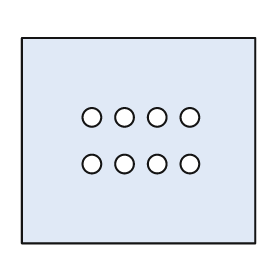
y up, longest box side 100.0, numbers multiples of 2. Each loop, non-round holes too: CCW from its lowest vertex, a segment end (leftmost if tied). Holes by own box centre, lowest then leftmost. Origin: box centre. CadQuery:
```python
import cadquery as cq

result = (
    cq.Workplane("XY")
    .moveTo(-50.0, -44.0)
    .lineTo(50.0, -44.0)
    .lineTo(50.0, 44.0)
    .lineTo(-50.0, 44.0)
    .close()
    .moveTo(-20.0, -10.0)
    .circle(4.0)
    .moveTo(-6.0, -10.0)
    .circle(4.0)
    .moveTo(8.0, -10.0)
    .circle(4.0)
    .moveTo(22.0, -10.0)
    .circle(4.0)
    .moveTo(-20.0, 10.0)
    .circle(4.0)
    .moveTo(-6.0, 10.0)
    .circle(4.0)
    .moveTo(8.0, 10.0)
    .circle(4.0)
    .moveTo(22.0, 10.0)
    .circle(4.0)
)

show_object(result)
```